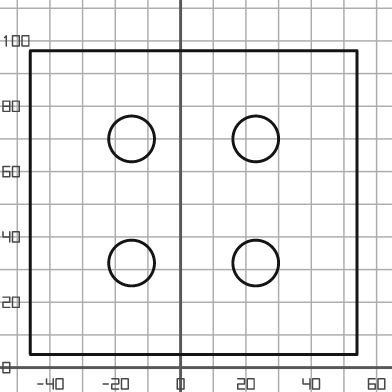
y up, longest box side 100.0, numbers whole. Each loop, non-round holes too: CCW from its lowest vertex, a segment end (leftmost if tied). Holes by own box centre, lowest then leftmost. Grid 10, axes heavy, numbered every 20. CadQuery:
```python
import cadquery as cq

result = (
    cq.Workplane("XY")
    .moveTo(-46.0, 4.0)
    .lineTo(54.0, 4.0)
    .lineTo(54.0, 97.0)
    .lineTo(-46.0, 97.0)
    .close()
    .moveTo(-15.0, 32.0)
    .circle(7.0)
    .moveTo(23.0, 32.0)
    .circle(7.0)
    .moveTo(-15.0, 70.0)
    .circle(7.0)
    .moveTo(23.0, 70.0)
    .circle(7.0)
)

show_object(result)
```